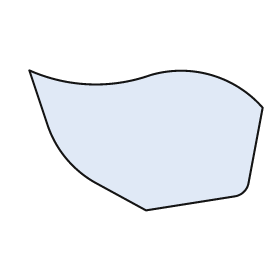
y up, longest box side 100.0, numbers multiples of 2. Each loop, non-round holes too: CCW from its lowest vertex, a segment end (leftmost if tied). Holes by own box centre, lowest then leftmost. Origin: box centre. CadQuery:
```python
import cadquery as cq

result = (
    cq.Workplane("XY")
    .moveTo(0.0, -30.0)
    .lineTo(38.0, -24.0)
    .threePointArc((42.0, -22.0), (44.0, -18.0))
    .lineTo(50.0, 14.0)
    .threePointArc((28.0, 28.0), (2.0, 28.0))
    .threePointArc((-24.0, 24.0), (-50.0, 30.0))
    .lineTo(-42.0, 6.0)
    .threePointArc((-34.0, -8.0), (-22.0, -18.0))
    .close()
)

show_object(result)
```